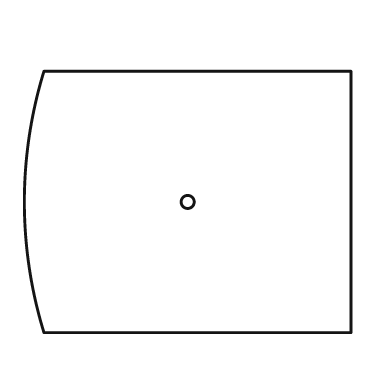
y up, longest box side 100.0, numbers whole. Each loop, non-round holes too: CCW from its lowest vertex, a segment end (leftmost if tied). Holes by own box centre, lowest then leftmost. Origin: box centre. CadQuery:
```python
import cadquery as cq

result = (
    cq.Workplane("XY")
    .moveTo(-44.0, -40.0)
    .lineTo(50.0, -40.0)
    .lineTo(50.0, 40.0)
    .lineTo(-44.0, 40.0)
    .threePointArc((-50.0, 0.0), (-44.0, -40.0))
    .close()
    .moveTo(0.0, 0.0)
    .circle(2.0)
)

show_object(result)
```